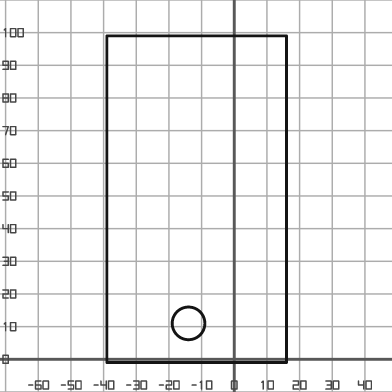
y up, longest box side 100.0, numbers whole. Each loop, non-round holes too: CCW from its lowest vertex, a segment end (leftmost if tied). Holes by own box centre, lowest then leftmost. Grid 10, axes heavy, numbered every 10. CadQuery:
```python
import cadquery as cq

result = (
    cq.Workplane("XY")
    .moveTo(-39.0, -1.0)
    .lineTo(16.0, -1.0)
    .lineTo(16.0, 99.0)
    .lineTo(-39.0, 99.0)
    .close()
    .moveTo(-14.0, 11.0)
    .circle(5.0)
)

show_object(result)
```